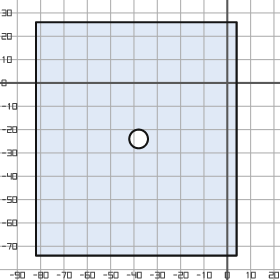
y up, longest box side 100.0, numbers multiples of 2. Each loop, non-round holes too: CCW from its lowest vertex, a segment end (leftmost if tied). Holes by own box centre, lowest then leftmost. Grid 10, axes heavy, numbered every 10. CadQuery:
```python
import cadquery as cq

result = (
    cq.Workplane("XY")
    .moveTo(-82.0, -74.0)
    .lineTo(4.0, -74.0)
    .lineTo(4.0, 26.0)
    .lineTo(-82.0, 26.0)
    .close()
    .moveTo(-38.0, -24.0)
    .circle(4.0)
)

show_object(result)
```